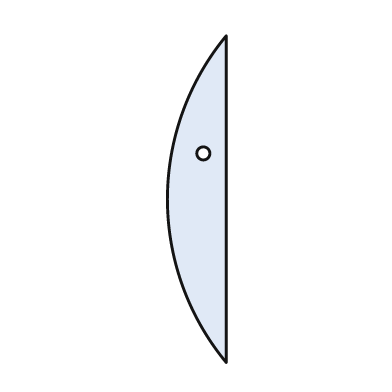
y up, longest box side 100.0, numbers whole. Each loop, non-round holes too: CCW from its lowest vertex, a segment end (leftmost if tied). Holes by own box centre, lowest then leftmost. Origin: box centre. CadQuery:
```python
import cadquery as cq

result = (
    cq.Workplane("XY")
    .moveTo(9.0, -50.0)
    .lineTo(9.0, 50.0)
    .threePointArc((-9.0, 0.0), (9.0, -50.0))
    .close()
    .moveTo(2.0, 14.0)
    .circle(2.0)
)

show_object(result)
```